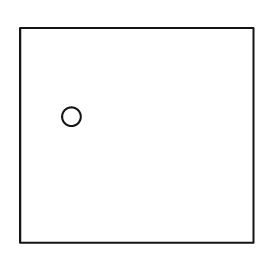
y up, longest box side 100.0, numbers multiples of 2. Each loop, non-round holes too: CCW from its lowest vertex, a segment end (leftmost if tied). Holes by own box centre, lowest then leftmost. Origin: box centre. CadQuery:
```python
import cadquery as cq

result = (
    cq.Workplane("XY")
    .moveTo(-50.0, -46.0)
    .lineTo(50.0, -46.0)
    .lineTo(50.0, 46.0)
    .lineTo(-50.0, 46.0)
    .close()
    .moveTo(-28.0, 8.0)
    .circle(4.0)
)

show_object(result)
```